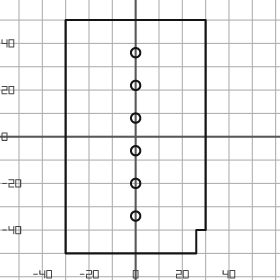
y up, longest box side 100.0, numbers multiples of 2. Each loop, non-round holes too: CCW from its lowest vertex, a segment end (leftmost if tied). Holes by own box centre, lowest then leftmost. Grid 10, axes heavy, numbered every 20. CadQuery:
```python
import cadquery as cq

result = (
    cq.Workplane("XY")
    .moveTo(-30.0, -50.0)
    .lineTo(26.0, -50.0)
    .lineTo(26.0, -40.0)
    .lineTo(30.0, -40.0)
    .lineTo(30.0, 50.0)
    .lineTo(-30.0, 50.0)
    .close()
    .moveTo(0.0, -34.0)
    .circle(2.0)
    .moveTo(0.0, -20.0)
    .circle(2.0)
    .moveTo(0.0, -6.0)
    .circle(2.0)
    .moveTo(0.0, 8.0)
    .circle(2.0)
    .moveTo(0.0, 22.0)
    .circle(2.0)
    .moveTo(0.0, 36.0)
    .circle(2.0)
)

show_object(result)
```